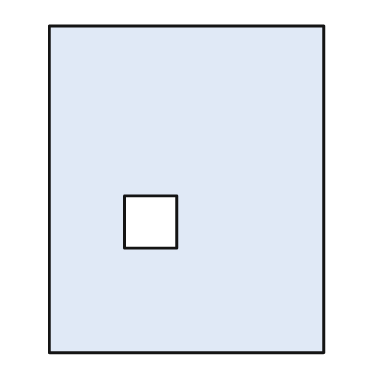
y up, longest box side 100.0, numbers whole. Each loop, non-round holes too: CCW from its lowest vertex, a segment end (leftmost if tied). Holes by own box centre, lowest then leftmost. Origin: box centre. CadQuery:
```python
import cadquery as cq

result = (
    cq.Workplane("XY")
    .moveTo(-42.0, -50.0)
    .lineTo(42.0, -50.0)
    .lineTo(42.0, 50.0)
    .lineTo(-42.0, 50.0)
    .close()
    .moveTo(-19.0, -18.0)
    .lineTo(-3.0, -18.0)
    .lineTo(-3.0, -2.0)
    .lineTo(-19.0, -2.0)
    .close()
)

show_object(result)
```